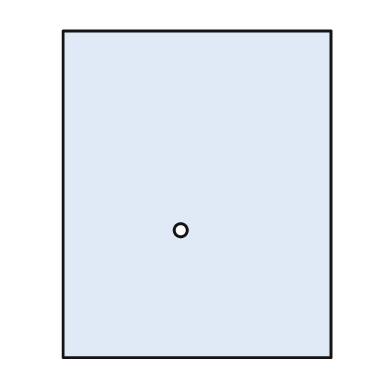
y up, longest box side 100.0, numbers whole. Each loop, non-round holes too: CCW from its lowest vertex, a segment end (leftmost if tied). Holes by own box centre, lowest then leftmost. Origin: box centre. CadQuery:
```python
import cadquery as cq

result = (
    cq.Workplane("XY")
    .moveTo(-41.0, -50.0)
    .lineTo(41.0, -50.0)
    .lineTo(41.0, 50.0)
    .lineTo(-41.0, 50.0)
    .close()
    .moveTo(-5.0, -11.0)
    .circle(2.0)
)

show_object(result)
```